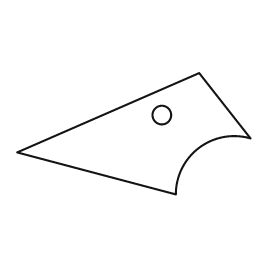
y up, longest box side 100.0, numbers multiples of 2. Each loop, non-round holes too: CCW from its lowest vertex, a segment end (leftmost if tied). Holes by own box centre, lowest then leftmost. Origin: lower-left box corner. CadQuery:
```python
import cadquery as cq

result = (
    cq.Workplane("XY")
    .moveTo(68.0, 0.0)
    .threePointArc((78.0, 20.0), (100.0, 24.0))
    .lineTo(78.0, 52.0)
    .lineTo(0.0, 18.0)
    .close()
    .moveTo(62.0, 34.0)
    .circle(4.0)
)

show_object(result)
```